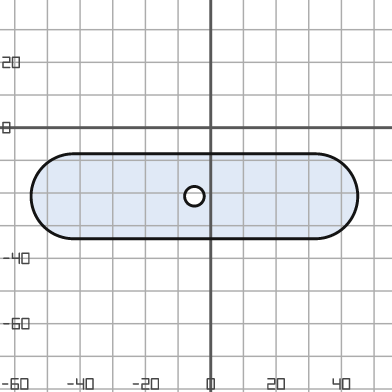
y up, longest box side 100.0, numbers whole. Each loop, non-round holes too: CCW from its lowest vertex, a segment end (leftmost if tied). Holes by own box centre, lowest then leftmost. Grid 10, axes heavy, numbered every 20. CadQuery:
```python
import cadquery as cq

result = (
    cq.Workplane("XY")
    .moveTo(-42.0, -34.0)
    .lineTo(32.0, -34.0)
    .threePointArc((45.0, -21.0), (32.0, -8.0))
    .lineTo(-42.0, -8.0)
    .threePointArc((-55.0, -21.0), (-42.0, -34.0))
    .close()
    .moveTo(-5.0, -21.0)
    .circle(3.0)
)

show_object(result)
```